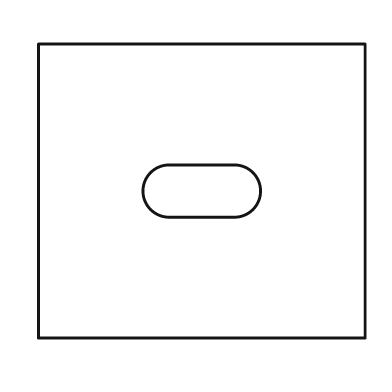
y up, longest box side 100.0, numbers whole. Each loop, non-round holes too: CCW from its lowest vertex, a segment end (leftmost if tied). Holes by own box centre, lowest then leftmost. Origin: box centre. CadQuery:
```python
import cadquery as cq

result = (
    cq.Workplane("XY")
    .moveTo(-50.0, -45.0)
    .lineTo(50.0, -45.0)
    .lineTo(50.0, 45.0)
    .lineTo(-50.0, 45.0)
    .close()
    .moveTo(-10.0, -8.0)
    .lineTo(10.0, -8.0)
    .threePointArc((18.0, 0.0), (10.0, 8.0))
    .lineTo(-10.0, 8.0)
    .threePointArc((-18.0, 0.0), (-10.0, -8.0))
    .close()
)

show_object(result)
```